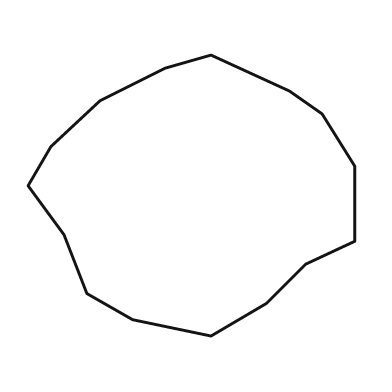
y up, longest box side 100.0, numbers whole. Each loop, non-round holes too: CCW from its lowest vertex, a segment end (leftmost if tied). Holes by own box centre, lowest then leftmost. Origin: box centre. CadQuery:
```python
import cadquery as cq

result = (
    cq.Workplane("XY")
    .moveTo(6.0, -43.0)
    .lineTo(23.0, -33.0)
    .lineTo(35.0, -21.0)
    .lineTo(50.0, -14.0)
    .lineTo(50.0, 9.0)
    .lineTo(40.0, 25.0)
    .lineTo(30.0, 32.0)
    .lineTo(6.0, 43.0)
    .lineTo(-8.0, 39.0)
    .lineTo(-28.0, 29.0)
    .lineTo(-43.0, 15.0)
    .lineTo(-50.0, 3.0)
    .lineTo(-39.0, -12.0)
    .lineTo(-32.0, -30.0)
    .lineTo(-18.0, -38.0)
    .close()
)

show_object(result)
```